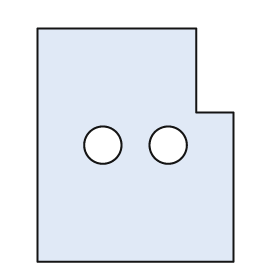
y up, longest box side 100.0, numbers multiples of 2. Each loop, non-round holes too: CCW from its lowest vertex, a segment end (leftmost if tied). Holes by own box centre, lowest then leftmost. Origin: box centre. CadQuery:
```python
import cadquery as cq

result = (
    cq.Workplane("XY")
    .moveTo(-42.0, -50.0)
    .lineTo(42.0, -50.0)
    .lineTo(42.0, 14.0)
    .lineTo(26.0, 14.0)
    .lineTo(26.0, 50.0)
    .lineTo(-42.0, 50.0)
    .close()
    .moveTo(-14.0, 0.0)
    .circle(8.0)
    .moveTo(14.0, 0.0)
    .circle(8.0)
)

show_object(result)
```